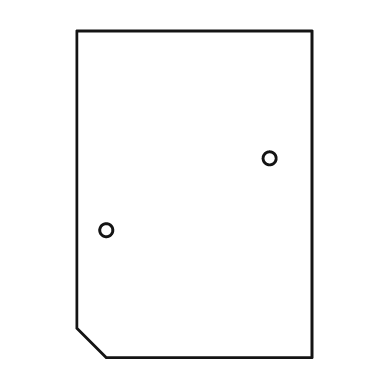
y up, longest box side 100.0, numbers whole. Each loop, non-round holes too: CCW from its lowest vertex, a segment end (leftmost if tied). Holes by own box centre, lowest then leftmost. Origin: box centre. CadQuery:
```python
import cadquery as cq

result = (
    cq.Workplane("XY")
    .moveTo(-27.0, -50.0)
    .lineTo(36.0, -50.0)
    .lineTo(36.0, 50.0)
    .lineTo(-36.0, 50.0)
    .lineTo(-36.0, -41.0)
    .close()
    .moveTo(-27.0, -11.0)
    .circle(2.0)
    .moveTo(23.0, 11.0)
    .circle(2.0)
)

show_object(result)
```